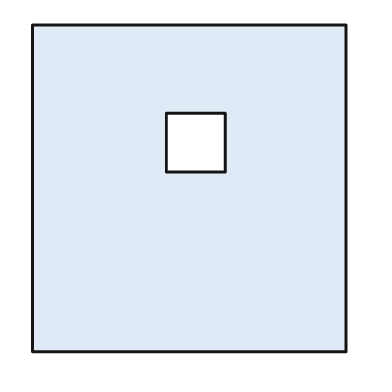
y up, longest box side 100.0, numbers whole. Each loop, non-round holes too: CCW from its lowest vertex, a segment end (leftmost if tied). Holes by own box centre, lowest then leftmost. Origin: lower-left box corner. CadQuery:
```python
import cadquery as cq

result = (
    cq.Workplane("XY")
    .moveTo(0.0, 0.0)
    .lineTo(96.0, 0.0)
    .lineTo(96.0, 100.0)
    .lineTo(0.0, 100.0)
    .close()
    .moveTo(41.0, 55.0)
    .lineTo(59.0, 55.0)
    .lineTo(59.0, 73.0)
    .lineTo(41.0, 73.0)
    .close()
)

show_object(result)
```